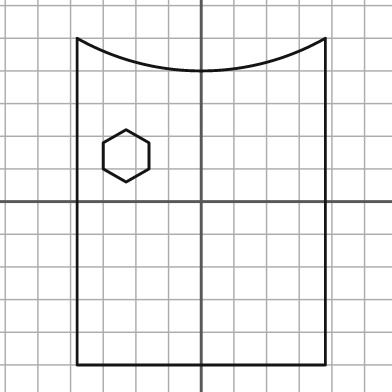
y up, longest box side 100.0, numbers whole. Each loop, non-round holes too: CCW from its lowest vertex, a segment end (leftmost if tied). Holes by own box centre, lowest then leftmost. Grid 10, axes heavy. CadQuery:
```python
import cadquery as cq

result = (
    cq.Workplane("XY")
    .moveTo(-38.0, -50.0)
    .lineTo(38.0, -50.0)
    .lineTo(38.0, 50.0)
    .threePointArc((0.0, 40.0), (-38.0, 50.0))
    .close()
    .moveTo(-23.0, 6.0)
    .lineTo(-16.0, 10.0)
    .lineTo(-16.0, 18.0)
    .lineTo(-23.0, 22.0)
    .lineTo(-30.0, 18.0)
    .lineTo(-30.0, 10.0)
    .close()
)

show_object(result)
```